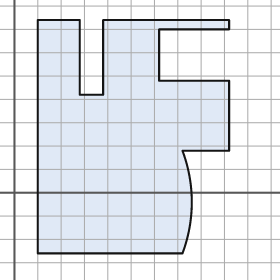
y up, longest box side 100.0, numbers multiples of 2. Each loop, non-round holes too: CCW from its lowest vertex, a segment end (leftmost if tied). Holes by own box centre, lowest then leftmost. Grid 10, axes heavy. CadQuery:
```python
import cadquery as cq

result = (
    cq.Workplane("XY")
    .moveTo(10.0, -26.0)
    .lineTo(72.0, -26.0)
    .threePointArc((76.0, -4.0), (72.0, 18.0))
    .lineTo(92.0, 18.0)
    .lineTo(92.0, 48.0)
    .lineTo(62.0, 48.0)
    .lineTo(62.0, 70.0)
    .lineTo(92.0, 70.0)
    .lineTo(92.0, 74.0)
    .lineTo(38.0, 74.0)
    .lineTo(38.0, 42.0)
    .lineTo(28.0, 42.0)
    .lineTo(28.0, 74.0)
    .lineTo(10.0, 74.0)
    .close()
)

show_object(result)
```